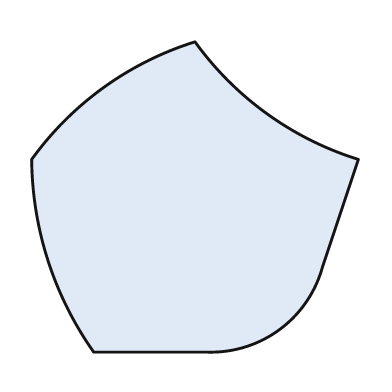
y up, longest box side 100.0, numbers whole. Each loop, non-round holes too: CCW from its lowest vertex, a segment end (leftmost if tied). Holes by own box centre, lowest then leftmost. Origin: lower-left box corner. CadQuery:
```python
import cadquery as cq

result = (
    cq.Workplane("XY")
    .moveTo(19.0, 0.0)
    .lineTo(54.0, 0.0)
    .threePointArc((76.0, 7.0), (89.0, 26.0))
    .lineTo(100.0, 59.0)
    .threePointArc((72.0, 73.0), (50.0, 95.0))
    .threePointArc((22.0, 81.0), (0.0, 59.0))
    .threePointArc((5.0, 28.0), (19.0, 0.0))
    .close()
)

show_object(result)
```